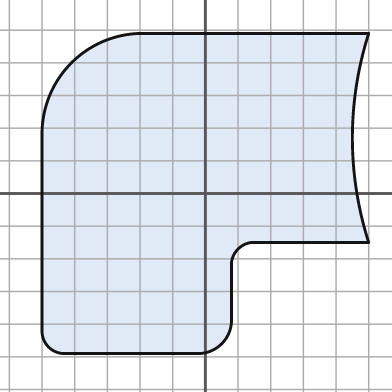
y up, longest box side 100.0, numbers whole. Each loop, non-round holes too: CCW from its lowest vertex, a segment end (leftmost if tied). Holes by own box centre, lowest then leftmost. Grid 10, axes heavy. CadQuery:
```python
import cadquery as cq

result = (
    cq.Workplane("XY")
    .moveTo(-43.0, -49.0)
    .lineTo(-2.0, -49.0)
    .threePointArc((5.0, -46.0), (8.0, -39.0))
    .lineTo(8.0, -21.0)
    .threePointArc((10.0, -17.0), (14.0, -15.0))
    .lineTo(50.0, -15.0)
    .threePointArc((45.0, 17.0), (50.0, 49.0))
    .lineTo(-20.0, 49.0)
    .threePointArc((-41.0, 40.0), (-50.0, 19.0))
    .lineTo(-50.0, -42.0)
    .threePointArc((-48.0, -47.0), (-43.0, -49.0))
    .close()
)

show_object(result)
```